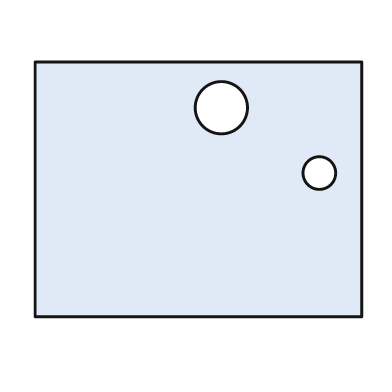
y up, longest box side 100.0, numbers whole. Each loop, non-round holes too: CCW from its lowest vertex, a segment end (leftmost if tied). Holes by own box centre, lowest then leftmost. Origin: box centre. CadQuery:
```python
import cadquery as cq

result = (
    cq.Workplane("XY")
    .moveTo(-50.0, -39.0)
    .lineTo(50.0, -39.0)
    .lineTo(50.0, 39.0)
    .lineTo(-50.0, 39.0)
    .close()
    .moveTo(37.0, 5.0)
    .circle(5.0)
    .moveTo(7.0, 25.0)
    .circle(8.0)
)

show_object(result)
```